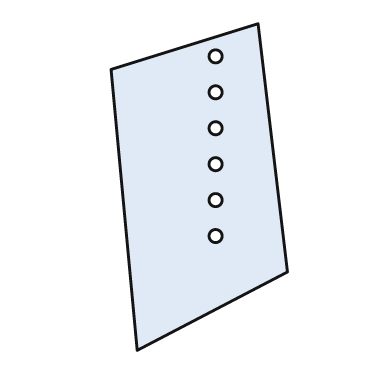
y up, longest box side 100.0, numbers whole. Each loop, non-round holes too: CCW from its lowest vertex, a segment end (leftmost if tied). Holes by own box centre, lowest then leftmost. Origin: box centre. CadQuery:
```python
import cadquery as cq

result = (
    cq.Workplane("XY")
    .moveTo(-19.0, -50.0)
    .lineTo(27.0, -26.0)
    .lineTo(18.0, 50.0)
    .lineTo(-27.0, 36.0)
    .close()
    .moveTo(5.0, -15.0)
    .circle(2.0)
    .moveTo(5.0, -4.0)
    .circle(2.0)
    .moveTo(5.0, 7.0)
    .circle(2.0)
    .moveTo(5.0, 18.0)
    .circle(2.0)
    .moveTo(5.0, 29.0)
    .circle(2.0)
    .moveTo(5.0, 40.0)
    .circle(2.0)
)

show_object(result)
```